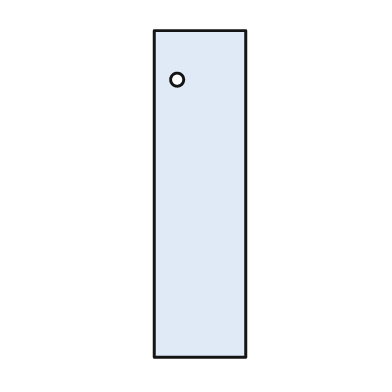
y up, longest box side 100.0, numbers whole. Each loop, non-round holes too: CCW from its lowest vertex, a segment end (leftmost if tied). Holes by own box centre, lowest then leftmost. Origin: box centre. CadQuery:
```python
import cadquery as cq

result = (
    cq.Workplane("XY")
    .moveTo(-14.0, -50.0)
    .lineTo(14.0, -50.0)
    .lineTo(14.0, 50.0)
    .lineTo(-14.0, 50.0)
    .close()
    .moveTo(-7.0, 35.0)
    .circle(2.0)
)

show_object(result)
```